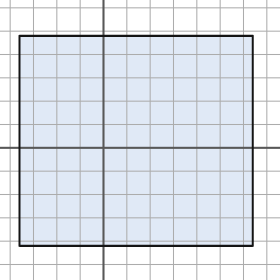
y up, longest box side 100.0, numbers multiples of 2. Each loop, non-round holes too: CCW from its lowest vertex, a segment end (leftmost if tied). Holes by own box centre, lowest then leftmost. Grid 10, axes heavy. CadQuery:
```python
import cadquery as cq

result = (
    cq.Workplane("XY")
    .moveTo(-36.0, -42.0)
    .lineTo(64.0, -42.0)
    .lineTo(64.0, 48.0)
    .lineTo(-36.0, 48.0)
    .close()
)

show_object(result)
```